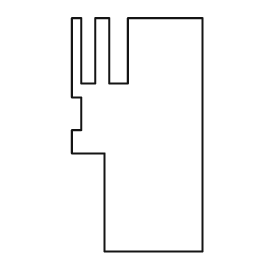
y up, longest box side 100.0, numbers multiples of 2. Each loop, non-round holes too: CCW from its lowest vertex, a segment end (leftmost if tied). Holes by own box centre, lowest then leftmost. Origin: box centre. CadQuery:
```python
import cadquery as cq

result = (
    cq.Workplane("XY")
    .moveTo(-14.0, -50.0)
    .lineTo(28.0, -50.0)
    .lineTo(28.0, 50.0)
    .lineTo(-4.0, 50.0)
    .lineTo(-4.0, 22.0)
    .lineTo(-12.0, 22.0)
    .lineTo(-12.0, 50.0)
    .lineTo(-18.0, 50.0)
    .lineTo(-18.0, 22.0)
    .lineTo(-24.0, 22.0)
    .lineTo(-24.0, 50.0)
    .lineTo(-28.0, 50.0)
    .lineTo(-28.0, 16.0)
    .lineTo(-24.0, 16.0)
    .lineTo(-24.0, 2.0)
    .lineTo(-28.0, 2.0)
    .lineTo(-28.0, -8.0)
    .lineTo(-14.0, -8.0)
    .close()
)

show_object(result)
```